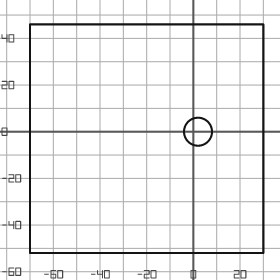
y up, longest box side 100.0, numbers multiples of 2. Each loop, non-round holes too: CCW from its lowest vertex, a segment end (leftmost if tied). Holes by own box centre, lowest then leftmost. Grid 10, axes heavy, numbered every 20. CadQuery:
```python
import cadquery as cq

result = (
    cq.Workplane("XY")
    .moveTo(-70.0, -52.0)
    .lineTo(30.0, -52.0)
    .lineTo(30.0, 46.0)
    .lineTo(-70.0, 46.0)
    .close()
    .moveTo(2.0, 0.0)
    .circle(6.0)
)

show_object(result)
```